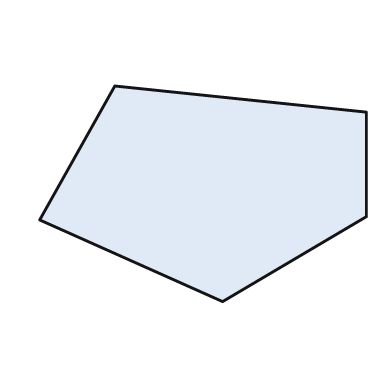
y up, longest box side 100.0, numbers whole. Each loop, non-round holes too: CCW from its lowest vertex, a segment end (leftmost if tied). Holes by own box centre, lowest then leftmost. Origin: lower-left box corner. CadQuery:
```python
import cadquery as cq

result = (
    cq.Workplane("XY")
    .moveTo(56.0, 0.0)
    .lineTo(100.0, 26.0)
    .lineTo(100.0, 58.0)
    .lineTo(23.0, 66.0)
    .lineTo(0.0, 25.0)
    .close()
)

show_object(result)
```